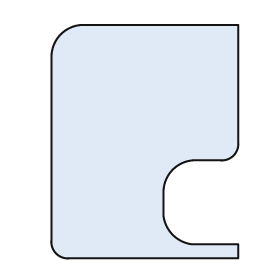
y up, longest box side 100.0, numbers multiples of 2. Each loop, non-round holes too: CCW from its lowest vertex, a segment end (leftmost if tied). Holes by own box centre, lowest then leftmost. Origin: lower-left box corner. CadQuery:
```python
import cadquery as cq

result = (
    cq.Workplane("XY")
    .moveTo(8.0, 0.0)
    .lineTo(80.0, 0.0)
    .lineTo(80.0, 6.0)
    .lineTo(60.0, 6.0)
    .threePointArc((52.0, 10.0), (48.0, 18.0))
    .lineTo(48.0, 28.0)
    .threePointArc((52.0, 38.0), (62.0, 42.0))
    .lineTo(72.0, 42.0)
    .threePointArc((78.0, 44.0), (80.0, 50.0))
    .lineTo(80.0, 100.0)
    .lineTo(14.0, 100.0)
    .threePointArc((4.0, 96.0), (0.0, 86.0))
    .lineTo(0.0, 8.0)
    .threePointArc((2.0, 2.0), (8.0, 0.0))
    .close()
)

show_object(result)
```